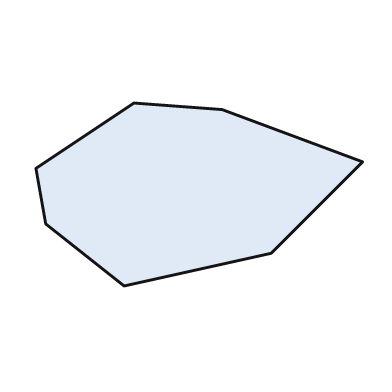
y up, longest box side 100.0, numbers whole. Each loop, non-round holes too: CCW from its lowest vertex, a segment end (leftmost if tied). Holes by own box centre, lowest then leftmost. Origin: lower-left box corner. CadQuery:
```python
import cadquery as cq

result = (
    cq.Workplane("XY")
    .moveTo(27.0, 0.0)
    .lineTo(72.0, 10.0)
    .lineTo(100.0, 38.0)
    .lineTo(57.0, 54.0)
    .lineTo(30.0, 56.0)
    .lineTo(0.0, 36.0)
    .lineTo(3.0, 19.0)
    .close()
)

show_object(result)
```